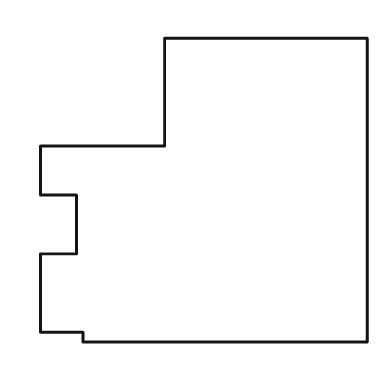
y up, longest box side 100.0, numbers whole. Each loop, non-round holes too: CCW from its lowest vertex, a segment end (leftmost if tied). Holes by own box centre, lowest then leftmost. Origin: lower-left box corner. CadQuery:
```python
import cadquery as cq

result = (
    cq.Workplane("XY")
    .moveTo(13.0, 0.0)
    .lineTo(100.0, 0.0)
    .lineTo(100.0, 93.0)
    .lineTo(38.0, 93.0)
    .lineTo(38.0, 60.0)
    .lineTo(0.0, 60.0)
    .lineTo(0.0, 45.0)
    .lineTo(11.0, 45.0)
    .lineTo(11.0, 27.0)
    .lineTo(0.0, 27.0)
    .lineTo(0.0, 3.0)
    .lineTo(13.0, 3.0)
    .close()
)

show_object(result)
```